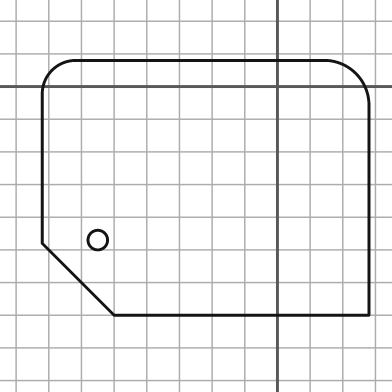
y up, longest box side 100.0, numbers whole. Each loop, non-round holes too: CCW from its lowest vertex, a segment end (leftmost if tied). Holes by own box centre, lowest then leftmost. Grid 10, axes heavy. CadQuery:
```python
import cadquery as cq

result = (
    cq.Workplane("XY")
    .moveTo(-50.0, -70.0)
    .lineTo(28.0, -70.0)
    .lineTo(28.0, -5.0)
    .threePointArc((24.0, 4.0), (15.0, 8.0))
    .lineTo(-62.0, 8.0)
    .threePointArc((-69.0, 5.0), (-72.0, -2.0))
    .lineTo(-72.0, -48.0)
    .close()
    .moveTo(-55.0, -47.0)
    .circle(3.0)
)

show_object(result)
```